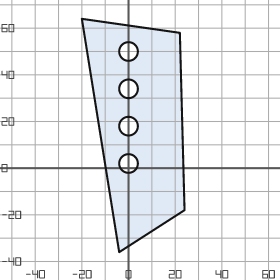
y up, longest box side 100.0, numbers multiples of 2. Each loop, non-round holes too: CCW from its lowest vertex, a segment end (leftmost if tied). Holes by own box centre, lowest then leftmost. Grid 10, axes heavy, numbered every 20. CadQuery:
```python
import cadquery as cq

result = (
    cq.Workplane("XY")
    .moveTo(-4.0, -36.0)
    .lineTo(24.0, -18.0)
    .lineTo(22.0, 58.0)
    .lineTo(-20.0, 64.0)
    .close()
    .moveTo(0.0, 2.0)
    .circle(4.0)
    .moveTo(0.0, 18.0)
    .circle(4.0)
    .moveTo(0.0, 34.0)
    .circle(4.0)
    .moveTo(0.0, 50.0)
    .circle(4.0)
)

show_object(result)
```